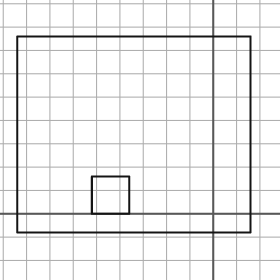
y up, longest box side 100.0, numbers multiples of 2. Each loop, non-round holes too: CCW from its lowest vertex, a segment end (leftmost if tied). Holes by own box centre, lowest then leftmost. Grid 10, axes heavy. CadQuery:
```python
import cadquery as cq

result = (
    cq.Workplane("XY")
    .moveTo(-84.0, -8.0)
    .lineTo(16.0, -8.0)
    .lineTo(16.0, 76.0)
    .lineTo(-84.0, 76.0)
    .close()
    .moveTo(-52.0, 0.0)
    .lineTo(-36.0, 0.0)
    .lineTo(-36.0, 16.0)
    .lineTo(-52.0, 16.0)
    .close()
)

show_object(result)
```